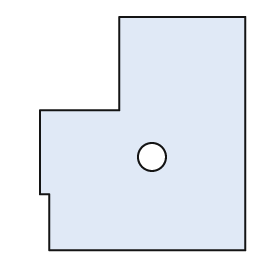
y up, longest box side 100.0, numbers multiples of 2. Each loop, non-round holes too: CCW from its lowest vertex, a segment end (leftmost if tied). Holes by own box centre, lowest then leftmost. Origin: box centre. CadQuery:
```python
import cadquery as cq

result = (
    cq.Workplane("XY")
    .moveTo(-40.0, -50.0)
    .lineTo(44.0, -50.0)
    .lineTo(44.0, 50.0)
    .lineTo(-10.0, 50.0)
    .lineTo(-10.0, 10.0)
    .lineTo(-44.0, 10.0)
    .lineTo(-44.0, -26.0)
    .lineTo(-40.0, -26.0)
    .close()
    .moveTo(4.0, -10.0)
    .circle(6.0)
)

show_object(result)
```